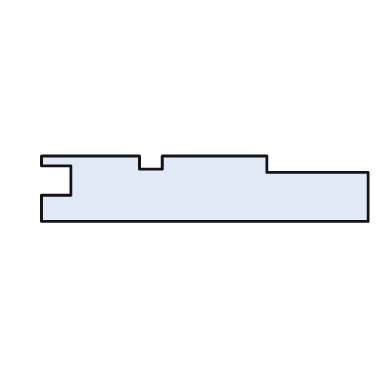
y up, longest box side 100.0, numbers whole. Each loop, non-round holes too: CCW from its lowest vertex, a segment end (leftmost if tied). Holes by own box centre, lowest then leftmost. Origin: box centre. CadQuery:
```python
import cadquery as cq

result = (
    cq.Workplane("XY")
    .moveTo(-50.0, -10.0)
    .lineTo(50.0, -10.0)
    .lineTo(50.0, 5.0)
    .lineTo(19.0, 5.0)
    .lineTo(19.0, 10.0)
    .lineTo(-13.0, 10.0)
    .lineTo(-13.0, 6.0)
    .lineTo(-20.0, 6.0)
    .lineTo(-20.0, 10.0)
    .lineTo(-50.0, 10.0)
    .lineTo(-50.0, 7.0)
    .lineTo(-41.0, 7.0)
    .lineTo(-41.0, -2.0)
    .lineTo(-50.0, -2.0)
    .close()
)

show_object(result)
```